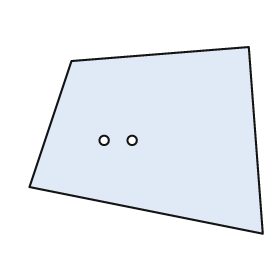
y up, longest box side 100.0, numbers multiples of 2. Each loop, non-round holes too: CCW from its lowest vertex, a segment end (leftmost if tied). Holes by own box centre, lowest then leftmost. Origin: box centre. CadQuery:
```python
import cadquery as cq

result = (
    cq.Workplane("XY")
    .moveTo(50.0, -40.0)
    .lineTo(44.0, 40.0)
    .lineTo(-32.0, 34.0)
    .lineTo(-50.0, -20.0)
    .close()
    .moveTo(-18.0, 0.0)
    .circle(2.0)
    .moveTo(-6.0, 0.0)
    .circle(2.0)
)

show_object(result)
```